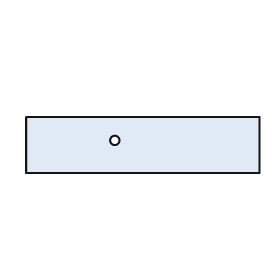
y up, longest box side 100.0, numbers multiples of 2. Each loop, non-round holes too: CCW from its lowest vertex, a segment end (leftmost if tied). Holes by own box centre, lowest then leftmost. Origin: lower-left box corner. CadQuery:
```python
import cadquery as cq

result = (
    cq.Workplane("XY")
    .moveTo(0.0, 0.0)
    .lineTo(100.0, 0.0)
    .lineTo(100.0, 24.0)
    .lineTo(0.0, 24.0)
    .close()
    .moveTo(38.0, 14.0)
    .circle(2.0)
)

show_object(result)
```